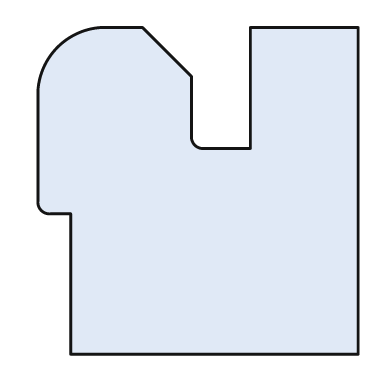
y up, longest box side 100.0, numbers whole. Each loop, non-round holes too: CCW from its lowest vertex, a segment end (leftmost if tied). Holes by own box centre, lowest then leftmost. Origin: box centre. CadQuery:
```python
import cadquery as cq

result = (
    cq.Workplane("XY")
    .moveTo(-39.0, -50.0)
    .lineTo(49.0, -50.0)
    .lineTo(49.0, 50.0)
    .lineTo(16.0, 50.0)
    .lineTo(16.0, 13.0)
    .lineTo(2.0, 13.0)
    .threePointArc((-1.0, 14.0), (-2.0, 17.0))
    .lineTo(-2.0, 35.0)
    .lineTo(-17.0, 50.0)
    .lineTo(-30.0, 50.0)
    .threePointArc((-43.0, 44.0), (-49.0, 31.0))
    .lineTo(-49.0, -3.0)
    .threePointArc((-48.0, -6.0), (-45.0, -7.0))
    .lineTo(-39.0, -7.0)
    .close()
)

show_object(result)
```